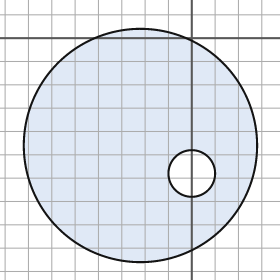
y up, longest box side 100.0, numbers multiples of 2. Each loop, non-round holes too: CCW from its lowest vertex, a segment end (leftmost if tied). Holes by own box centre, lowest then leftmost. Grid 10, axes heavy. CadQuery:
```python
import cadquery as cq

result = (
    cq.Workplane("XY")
    .moveTo(-22.0, -46.0)
    .circle(50.0)
    .moveTo(0.0, -58.0)
    .circle(10.0)
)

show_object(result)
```